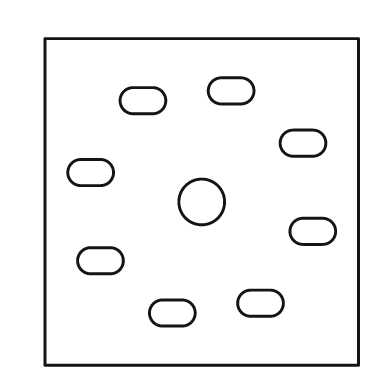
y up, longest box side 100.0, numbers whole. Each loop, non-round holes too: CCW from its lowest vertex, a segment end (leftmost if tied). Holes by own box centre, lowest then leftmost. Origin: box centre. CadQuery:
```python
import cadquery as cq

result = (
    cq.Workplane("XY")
    .moveTo(-48.0, -50.0)
    .lineTo(48.0, -50.0)
    .lineTo(48.0, 50.0)
    .lineTo(-48.0, 50.0)
    .close()
    .moveTo(-12.0, -38.0)
    .lineTo(-6.0, -38.0)
    .threePointArc((-2.0, -34.0), (-6.0, -30.0))
    .lineTo(-12.0, -30.0)
    .threePointArc((-16.0, -34.0), (-12.0, -38.0))
    .close()
    .moveTo(15.0, -35.0)
    .lineTo(21.0, -35.0)
    .threePointArc((25.0, -31.0), (21.0, -27.0))
    .lineTo(15.0, -27.0)
    .threePointArc((11.0, -31.0), (15.0, -35.0))
    .close()
    .moveTo(-34.0, -22.0)
    .lineTo(-28.0, -22.0)
    .threePointArc((-24.0, -18.0), (-28.0, -14.0))
    .lineTo(-34.0, -14.0)
    .threePointArc((-38.0, -18.0), (-34.0, -22.0))
    .close()
    .moveTo(31.0, -13.0)
    .lineTo(37.0, -13.0)
    .threePointArc((41.0, -9.0), (37.0, -5.0))
    .lineTo(31.0, -5.0)
    .threePointArc((27.0, -9.0), (31.0, -13.0))
    .close()
    .moveTo(0.0, 0.0)
    .circle(7.0)
    .moveTo(-37.0, 5.0)
    .lineTo(-31.0, 5.0)
    .threePointArc((-27.0, 9.0), (-31.0, 13.0))
    .lineTo(-37.0, 13.0)
    .threePointArc((-41.0, 9.0), (-37.0, 5.0))
    .close()
    .moveTo(28.0, 14.0)
    .lineTo(34.0, 14.0)
    .threePointArc((38.0, 18.0), (34.0, 22.0))
    .lineTo(28.0, 22.0)
    .threePointArc((24.0, 18.0), (28.0, 14.0))
    .close()
    .moveTo(-21.0, 27.0)
    .lineTo(-15.0, 27.0)
    .threePointArc((-11.0, 31.0), (-15.0, 35.0))
    .lineTo(-21.0, 35.0)
    .threePointArc((-25.0, 31.0), (-21.0, 27.0))
    .close()
    .moveTo(6.0, 30.0)
    .lineTo(12.0, 30.0)
    .threePointArc((16.0, 34.0), (12.0, 38.0))
    .lineTo(6.0, 38.0)
    .threePointArc((2.0, 34.0), (6.0, 30.0))
    .close()
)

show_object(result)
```